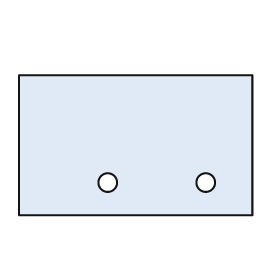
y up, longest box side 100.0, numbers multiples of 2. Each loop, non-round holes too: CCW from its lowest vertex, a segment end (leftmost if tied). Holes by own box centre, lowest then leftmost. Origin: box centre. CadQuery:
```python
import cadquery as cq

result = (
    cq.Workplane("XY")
    .moveTo(-50.0, -30.0)
    .lineTo(50.0, -30.0)
    .lineTo(50.0, 30.0)
    .lineTo(-50.0, 30.0)
    .close()
    .moveTo(-12.0, -16.0)
    .circle(4.0)
    .moveTo(30.0, -16.0)
    .circle(4.0)
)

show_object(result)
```